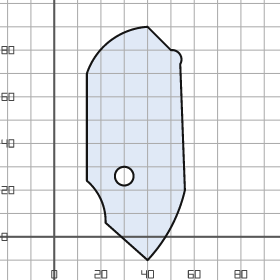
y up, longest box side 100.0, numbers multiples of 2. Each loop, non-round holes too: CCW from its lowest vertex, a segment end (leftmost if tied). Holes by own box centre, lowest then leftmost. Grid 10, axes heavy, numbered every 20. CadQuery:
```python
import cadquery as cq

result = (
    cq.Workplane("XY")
    .moveTo(40.0, -10.0)
    .threePointArc((50.0, 4.0), (56.0, 20.0))
    .lineTo(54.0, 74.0)
    .threePointArc((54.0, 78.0), (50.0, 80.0))
    .lineTo(40.0, 90.0)
    .threePointArc((24.0, 84.0), (14.0, 70.0))
    .lineTo(14.0, 24.0)
    .threePointArc((20.0, 16.0), (22.0, 6.0))
    .close()
    .moveTo(30.0, 26.0)
    .circle(4.0)
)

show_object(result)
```